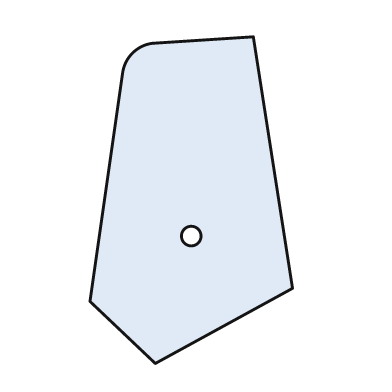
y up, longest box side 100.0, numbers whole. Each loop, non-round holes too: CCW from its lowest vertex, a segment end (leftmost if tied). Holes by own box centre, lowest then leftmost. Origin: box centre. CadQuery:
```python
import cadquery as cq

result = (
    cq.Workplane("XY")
    .moveTo(-11.0, -50.0)
    .lineTo(31.0, -27.0)
    .lineTo(19.0, 50.0)
    .lineTo(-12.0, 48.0)
    .threePointArc((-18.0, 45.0), (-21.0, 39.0))
    .lineTo(-31.0, -31.0)
    .close()
    .moveTo(0.0, -11.0)
    .circle(3.0)
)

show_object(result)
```